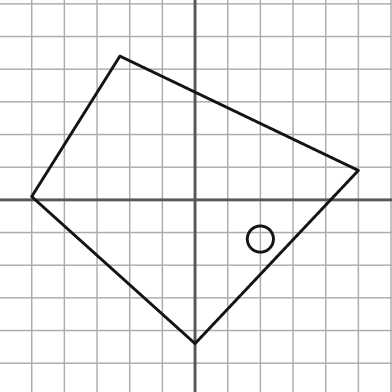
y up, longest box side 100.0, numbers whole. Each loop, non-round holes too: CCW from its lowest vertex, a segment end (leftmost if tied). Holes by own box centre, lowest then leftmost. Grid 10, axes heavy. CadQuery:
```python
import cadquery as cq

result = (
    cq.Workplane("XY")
    .moveTo(0.0, -44.0)
    .lineTo(50.0, 9.0)
    .lineTo(-23.0, 44.0)
    .lineTo(-50.0, 1.0)
    .close()
    .moveTo(20.0, -12.0)
    .circle(4.0)
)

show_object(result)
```